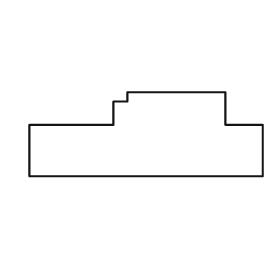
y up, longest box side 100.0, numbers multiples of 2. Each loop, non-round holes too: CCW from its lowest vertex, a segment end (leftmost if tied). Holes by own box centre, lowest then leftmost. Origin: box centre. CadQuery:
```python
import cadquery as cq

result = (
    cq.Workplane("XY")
    .moveTo(-50.0, -18.0)
    .lineTo(50.0, -18.0)
    .lineTo(50.0, 4.0)
    .lineTo(34.0, 4.0)
    .lineTo(34.0, 18.0)
    .lineTo(-8.0, 18.0)
    .lineTo(-8.0, 14.0)
    .lineTo(-14.0, 14.0)
    .lineTo(-14.0, 4.0)
    .lineTo(-50.0, 4.0)
    .close()
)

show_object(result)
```